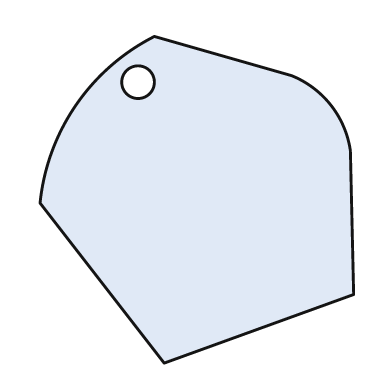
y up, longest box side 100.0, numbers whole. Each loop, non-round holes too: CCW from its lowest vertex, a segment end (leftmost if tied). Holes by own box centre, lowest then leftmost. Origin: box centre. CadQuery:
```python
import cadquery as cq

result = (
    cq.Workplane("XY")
    .moveTo(-10.0, -50.0)
    .lineTo(48.0, -29.0)
    .lineTo(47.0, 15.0)
    .threePointArc((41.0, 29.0), (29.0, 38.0))
    .lineTo(-13.0, 50.0)
    .threePointArc((-37.0, 29.0), (-48.0, -1.0))
    .close()
    .moveTo(-18.0, 36.0)
    .circle(5.0)
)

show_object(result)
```